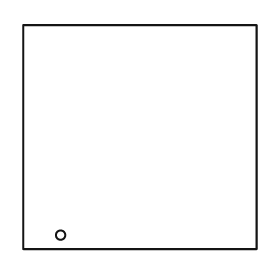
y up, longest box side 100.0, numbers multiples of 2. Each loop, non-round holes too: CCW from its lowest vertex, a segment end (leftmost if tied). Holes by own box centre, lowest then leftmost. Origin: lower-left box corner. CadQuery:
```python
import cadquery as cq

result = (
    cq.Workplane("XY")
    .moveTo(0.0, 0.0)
    .lineTo(100.0, 0.0)
    .lineTo(100.0, 96.0)
    .lineTo(0.0, 96.0)
    .close()
    .moveTo(16.0, 6.0)
    .circle(2.0)
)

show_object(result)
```